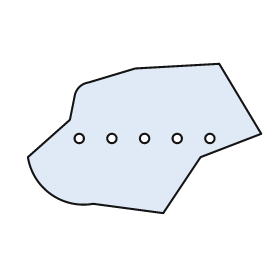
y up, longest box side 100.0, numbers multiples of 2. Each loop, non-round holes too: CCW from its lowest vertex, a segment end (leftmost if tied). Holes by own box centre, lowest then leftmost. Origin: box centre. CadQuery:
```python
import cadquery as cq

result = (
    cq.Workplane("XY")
    .moveTo(8.0, -32.0)
    .lineTo(24.0, -8.0)
    .lineTo(50.0, 2.0)
    .lineTo(32.0, 32.0)
    .lineTo(-4.0, 30.0)
    .lineTo(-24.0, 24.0)
    .threePointArc((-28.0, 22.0), (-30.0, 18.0))
    .lineTo(-32.0, 8.0)
    .lineTo(-50.0, -8.0)
    .threePointArc((-40.0, -24.0), (-22.0, -28.0))
    .close()
    .moveTo(-28.0, 0.0)
    .circle(2.0)
    .moveTo(-14.0, 0.0)
    .circle(2.0)
    .moveTo(0.0, 0.0)
    .circle(2.0)
    .moveTo(14.0, 0.0)
    .circle(2.0)
    .moveTo(28.0, 0.0)
    .circle(2.0)
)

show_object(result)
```